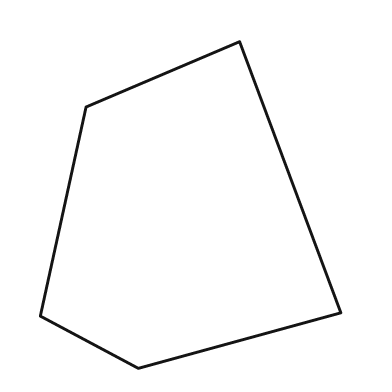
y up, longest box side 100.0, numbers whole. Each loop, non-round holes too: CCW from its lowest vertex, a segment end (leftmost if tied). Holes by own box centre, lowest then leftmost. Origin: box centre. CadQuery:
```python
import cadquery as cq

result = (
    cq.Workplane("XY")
    .moveTo(-16.0, -50.0)
    .lineTo(46.0, -33.0)
    .lineTo(15.0, 50.0)
    .lineTo(-32.0, 30.0)
    .lineTo(-46.0, -34.0)
    .close()
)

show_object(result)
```